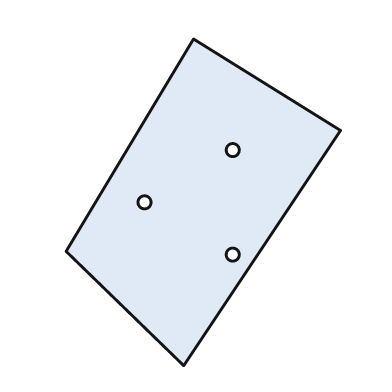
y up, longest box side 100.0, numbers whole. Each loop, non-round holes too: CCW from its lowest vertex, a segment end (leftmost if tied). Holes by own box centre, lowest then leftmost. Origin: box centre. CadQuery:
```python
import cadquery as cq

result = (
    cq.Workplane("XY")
    .moveTo(-6.0, -50.0)
    .lineTo(42.0, 22.0)
    .lineTo(-3.0, 50.0)
    .lineTo(-42.0, -15.0)
    .close()
    .moveTo(9.0, -16.0)
    .circle(2.0)
    .moveTo(-18.0, 0.0)
    .circle(2.0)
    .moveTo(9.0, 16.0)
    .circle(2.0)
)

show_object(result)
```